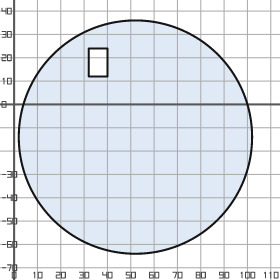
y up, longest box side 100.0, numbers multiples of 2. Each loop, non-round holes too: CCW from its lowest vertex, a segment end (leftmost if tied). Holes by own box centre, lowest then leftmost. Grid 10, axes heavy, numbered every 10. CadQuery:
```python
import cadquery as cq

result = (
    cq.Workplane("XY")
    .moveTo(52.0, -14.0)
    .circle(50.0)
    .moveTo(32.0, 12.0)
    .lineTo(40.0, 12.0)
    .lineTo(40.0, 24.0)
    .lineTo(32.0, 24.0)
    .close()
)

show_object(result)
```